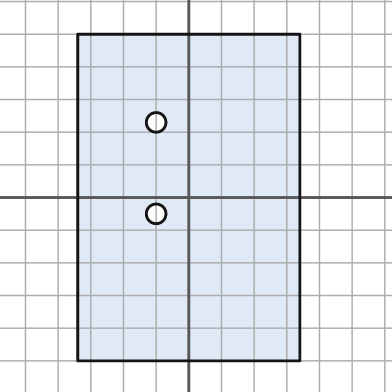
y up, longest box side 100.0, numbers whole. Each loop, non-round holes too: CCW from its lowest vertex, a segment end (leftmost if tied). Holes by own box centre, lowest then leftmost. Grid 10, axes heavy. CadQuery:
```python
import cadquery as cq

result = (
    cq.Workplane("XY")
    .moveTo(-34.0, -50.0)
    .lineTo(34.0, -50.0)
    .lineTo(34.0, 50.0)
    .lineTo(-34.0, 50.0)
    .close()
    .moveTo(-10.0, -5.0)
    .circle(3.0)
    .moveTo(-10.0, 23.0)
    .circle(3.0)
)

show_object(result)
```